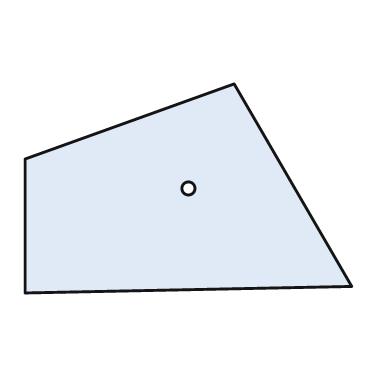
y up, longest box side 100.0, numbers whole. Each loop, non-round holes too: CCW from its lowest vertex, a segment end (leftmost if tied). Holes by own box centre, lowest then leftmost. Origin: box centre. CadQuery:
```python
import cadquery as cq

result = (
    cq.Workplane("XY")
    .moveTo(-50.0, -32.0)
    .lineTo(50.0, -30.0)
    .lineTo(14.0, 32.0)
    .lineTo(-50.0, 9.0)
    .close()
    .moveTo(0.0, 0.0)
    .circle(2.0)
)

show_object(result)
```